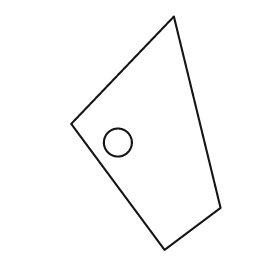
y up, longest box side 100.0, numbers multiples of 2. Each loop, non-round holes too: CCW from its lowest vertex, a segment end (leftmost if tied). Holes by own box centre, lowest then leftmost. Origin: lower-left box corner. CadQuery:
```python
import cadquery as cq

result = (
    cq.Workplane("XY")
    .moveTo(40.0, 0.0)
    .lineTo(64.0, 18.0)
    .lineTo(44.0, 100.0)
    .lineTo(0.0, 54.0)
    .close()
    .moveTo(20.0, 46.0)
    .circle(6.0)
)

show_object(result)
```